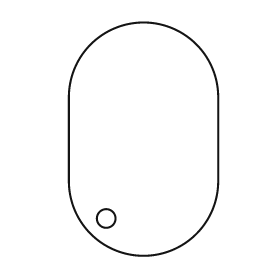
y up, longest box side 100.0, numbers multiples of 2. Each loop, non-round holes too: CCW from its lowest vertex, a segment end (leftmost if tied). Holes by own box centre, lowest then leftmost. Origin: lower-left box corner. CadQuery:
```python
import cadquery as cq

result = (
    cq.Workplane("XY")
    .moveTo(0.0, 32.0)
    .threePointArc((32.0, 0.0), (64.0, 32.0))
    .lineTo(64.0, 68.0)
    .threePointArc((32.0, 100.0), (0.0, 68.0))
    .close()
    .moveTo(16.0, 16.0)
    .circle(4.0)
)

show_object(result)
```